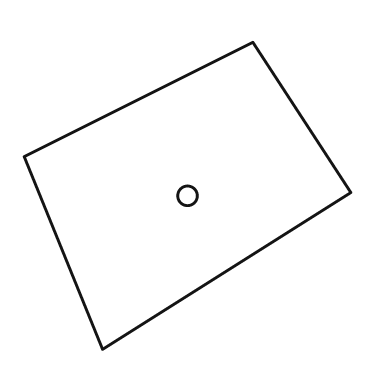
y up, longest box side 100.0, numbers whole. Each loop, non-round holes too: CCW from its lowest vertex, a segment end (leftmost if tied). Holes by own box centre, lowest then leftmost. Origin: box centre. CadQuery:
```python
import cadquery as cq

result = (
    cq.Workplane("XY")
    .moveTo(-26.0, -47.0)
    .lineTo(50.0, 1.0)
    .lineTo(20.0, 47.0)
    .lineTo(-50.0, 12.0)
    .close()
    .moveTo(0.0, 0.0)
    .circle(3.0)
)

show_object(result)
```